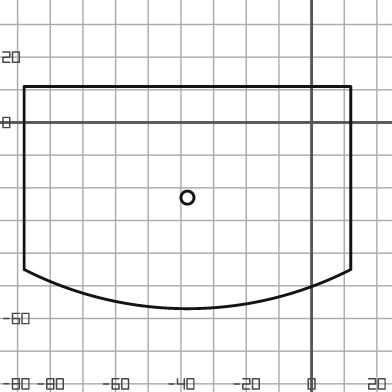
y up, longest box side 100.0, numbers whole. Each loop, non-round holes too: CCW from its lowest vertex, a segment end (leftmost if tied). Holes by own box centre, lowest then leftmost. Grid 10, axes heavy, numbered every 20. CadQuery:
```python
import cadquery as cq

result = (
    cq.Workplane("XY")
    .moveTo(-88.0, -45.0)
    .threePointArc((-38.0, -57.0), (12.0, -45.0))
    .lineTo(12.0, 11.0)
    .lineTo(-88.0, 11.0)
    .close()
    .moveTo(-38.0, -23.0)
    .circle(2.0)
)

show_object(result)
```